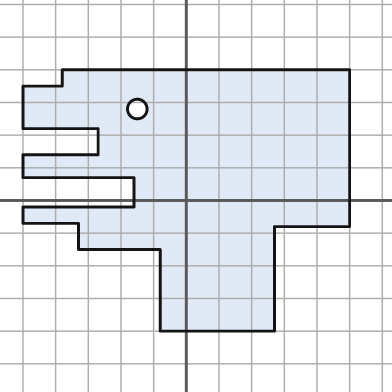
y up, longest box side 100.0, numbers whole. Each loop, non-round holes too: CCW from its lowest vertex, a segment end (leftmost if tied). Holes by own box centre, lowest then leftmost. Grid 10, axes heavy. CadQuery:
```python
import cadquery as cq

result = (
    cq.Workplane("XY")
    .moveTo(-8.0, -40.0)
    .lineTo(27.0, -40.0)
    .lineTo(27.0, -8.0)
    .lineTo(50.0, -8.0)
    .lineTo(50.0, 40.0)
    .lineTo(-38.0, 40.0)
    .lineTo(-38.0, 35.0)
    .lineTo(-50.0, 35.0)
    .lineTo(-50.0, 22.0)
    .lineTo(-27.0, 22.0)
    .lineTo(-27.0, 14.0)
    .lineTo(-50.0, 14.0)
    .lineTo(-50.0, 7.0)
    .lineTo(-16.0, 7.0)
    .lineTo(-16.0, -2.0)
    .lineTo(-50.0, -2.0)
    .lineTo(-50.0, -7.0)
    .lineTo(-33.0, -7.0)
    .lineTo(-33.0, -15.0)
    .lineTo(-8.0, -15.0)
    .close()
    .moveTo(-15.0, 28.0)
    .circle(3.0)
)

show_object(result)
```